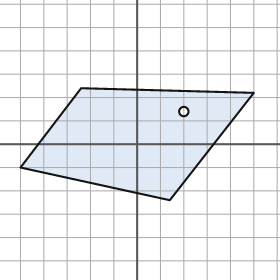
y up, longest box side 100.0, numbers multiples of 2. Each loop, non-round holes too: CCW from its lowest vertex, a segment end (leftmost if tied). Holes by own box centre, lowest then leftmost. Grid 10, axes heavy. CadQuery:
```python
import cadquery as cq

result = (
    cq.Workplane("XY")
    .moveTo(14.0, -24.0)
    .lineTo(50.0, 22.0)
    .lineTo(-24.0, 24.0)
    .lineTo(-50.0, -10.0)
    .close()
    .moveTo(20.0, 14.0)
    .circle(2.0)
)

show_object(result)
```